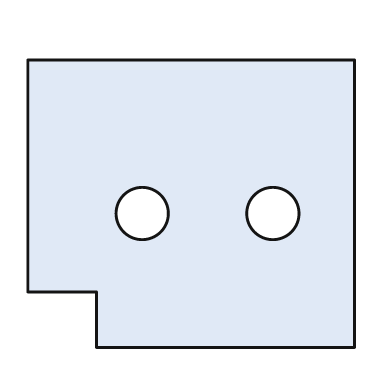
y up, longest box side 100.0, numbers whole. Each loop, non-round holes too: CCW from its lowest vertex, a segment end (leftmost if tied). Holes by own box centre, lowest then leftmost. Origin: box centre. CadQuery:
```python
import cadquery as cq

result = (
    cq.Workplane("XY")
    .moveTo(-29.0, -44.0)
    .lineTo(50.0, -44.0)
    .lineTo(50.0, 44.0)
    .lineTo(-50.0, 44.0)
    .lineTo(-50.0, -27.0)
    .lineTo(-29.0, -27.0)
    .close()
    .moveTo(-15.0, -3.0)
    .circle(8.0)
    .moveTo(25.0, -3.0)
    .circle(8.0)
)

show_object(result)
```